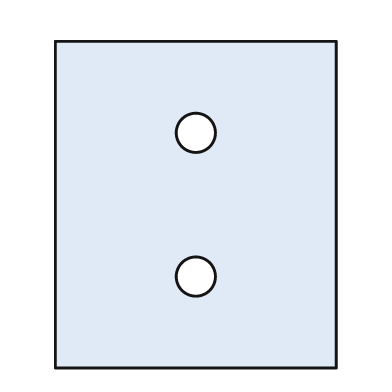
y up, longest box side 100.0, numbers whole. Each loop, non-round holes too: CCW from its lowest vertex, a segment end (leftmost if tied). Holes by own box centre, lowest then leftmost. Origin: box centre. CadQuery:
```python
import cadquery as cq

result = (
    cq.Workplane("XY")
    .moveTo(-43.0, -50.0)
    .lineTo(43.0, -50.0)
    .lineTo(43.0, 50.0)
    .lineTo(-43.0, 50.0)
    .close()
    .moveTo(0.0, -22.0)
    .circle(6.0)
    .moveTo(0.0, 22.0)
    .circle(6.0)
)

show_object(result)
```